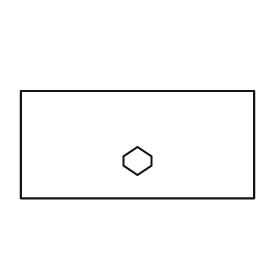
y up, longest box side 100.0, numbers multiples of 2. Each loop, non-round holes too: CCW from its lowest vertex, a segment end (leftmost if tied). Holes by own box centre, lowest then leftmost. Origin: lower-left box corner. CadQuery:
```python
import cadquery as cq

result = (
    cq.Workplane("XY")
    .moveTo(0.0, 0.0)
    .lineTo(100.0, 0.0)
    .lineTo(100.0, 46.0)
    .lineTo(0.0, 46.0)
    .close()
    .moveTo(50.0, 10.0)
    .lineTo(56.0, 14.0)
    .lineTo(56.0, 18.0)
    .lineTo(50.0, 22.0)
    .lineTo(44.0, 18.0)
    .lineTo(44.0, 14.0)
    .close()
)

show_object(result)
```